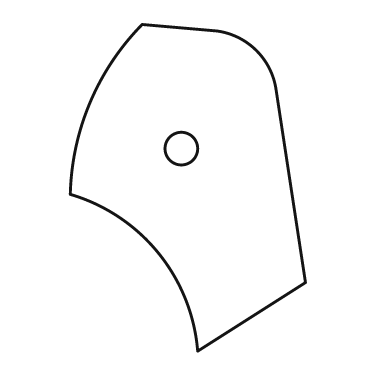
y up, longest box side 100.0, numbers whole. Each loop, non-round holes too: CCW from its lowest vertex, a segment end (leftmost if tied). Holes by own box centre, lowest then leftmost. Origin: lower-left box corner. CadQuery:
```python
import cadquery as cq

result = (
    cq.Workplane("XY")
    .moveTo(39.0, 0.0)
    .lineTo(72.0, 21.0)
    .lineTo(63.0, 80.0)
    .threePointArc((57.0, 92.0), (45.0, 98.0))
    .lineTo(22.0, 100.0)
    .threePointArc((6.0, 76.0), (0.0, 48.0))
    .threePointArc((27.0, 30.0), (39.0, 0.0))
    .close()
    .moveTo(34.0, 62.0)
    .circle(5.0)
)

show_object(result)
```